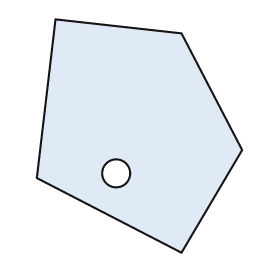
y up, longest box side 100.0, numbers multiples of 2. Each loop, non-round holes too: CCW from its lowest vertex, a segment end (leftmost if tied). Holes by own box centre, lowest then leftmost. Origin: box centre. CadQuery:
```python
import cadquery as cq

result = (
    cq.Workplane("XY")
    .moveTo(18.0, -50.0)
    .lineTo(44.0, -6.0)
    .lineTo(18.0, 44.0)
    .lineTo(-36.0, 50.0)
    .lineTo(-44.0, -18.0)
    .close()
    .moveTo(-10.0, -16.0)
    .circle(6.0)
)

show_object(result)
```